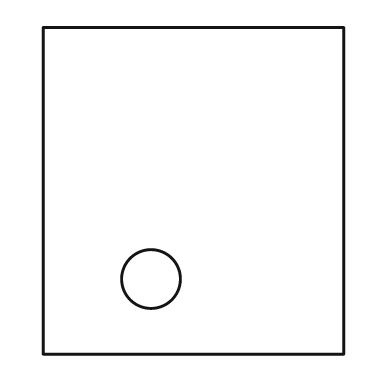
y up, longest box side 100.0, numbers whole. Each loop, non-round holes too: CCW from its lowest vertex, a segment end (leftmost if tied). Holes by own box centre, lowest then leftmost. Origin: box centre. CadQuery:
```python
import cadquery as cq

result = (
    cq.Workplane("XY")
    .moveTo(-46.0, -50.0)
    .lineTo(46.0, -50.0)
    .lineTo(46.0, 50.0)
    .lineTo(-46.0, 50.0)
    .close()
    .moveTo(-13.0, -27.0)
    .circle(9.0)
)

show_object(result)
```